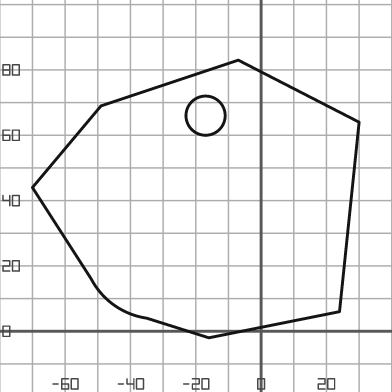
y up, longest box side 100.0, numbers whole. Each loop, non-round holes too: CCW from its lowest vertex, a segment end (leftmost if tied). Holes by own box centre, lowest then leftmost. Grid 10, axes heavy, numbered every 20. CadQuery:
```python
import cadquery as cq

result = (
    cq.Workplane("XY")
    .moveTo(-16.0, -2.0)
    .lineTo(24.0, 6.0)
    .lineTo(30.0, 64.0)
    .lineTo(-7.0, 83.0)
    .lineTo(-49.0, 69.0)
    .lineTo(-70.0, 44.0)
    .lineTo(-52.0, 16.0)
    .threePointArc((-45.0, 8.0), (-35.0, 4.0))
    .close()
    .moveTo(-17.0, 66.0)
    .circle(6.0)
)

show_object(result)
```